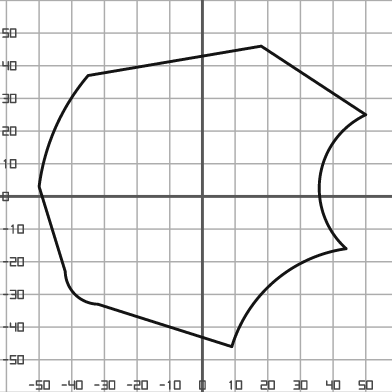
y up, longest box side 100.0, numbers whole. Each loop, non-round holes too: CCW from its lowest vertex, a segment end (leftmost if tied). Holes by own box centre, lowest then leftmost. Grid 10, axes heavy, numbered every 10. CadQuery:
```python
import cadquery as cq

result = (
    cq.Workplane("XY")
    .moveTo(9.0, -46.0)
    .threePointArc((22.0, -26.0), (44.0, -16.0))
    .threePointArc((36.0, 6.0), (50.0, 25.0))
    .lineTo(18.0, 46.0)
    .lineTo(-35.0, 37.0)
    .threePointArc((-45.0, 21.0), (-50.0, 3.0))
    .lineTo(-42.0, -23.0)
    .threePointArc((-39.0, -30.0), (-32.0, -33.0))
    .close()
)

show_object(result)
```